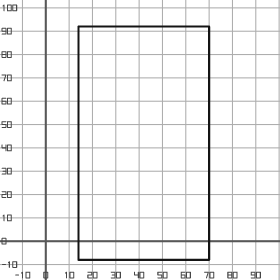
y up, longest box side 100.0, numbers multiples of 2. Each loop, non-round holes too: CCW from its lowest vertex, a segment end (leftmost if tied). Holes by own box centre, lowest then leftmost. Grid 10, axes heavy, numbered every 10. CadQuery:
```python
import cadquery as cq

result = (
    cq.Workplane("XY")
    .moveTo(14.0, -8.0)
    .lineTo(70.0, -8.0)
    .lineTo(70.0, 92.0)
    .lineTo(14.0, 92.0)
    .close()
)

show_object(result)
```